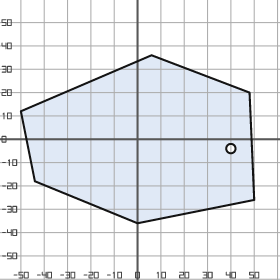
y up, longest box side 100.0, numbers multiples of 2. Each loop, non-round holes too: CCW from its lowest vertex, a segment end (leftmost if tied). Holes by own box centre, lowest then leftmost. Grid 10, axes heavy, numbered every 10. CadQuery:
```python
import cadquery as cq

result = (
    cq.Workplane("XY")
    .moveTo(0.0, -36.0)
    .lineTo(50.0, -26.0)
    .lineTo(48.0, 20.0)
    .lineTo(6.0, 36.0)
    .lineTo(-50.0, 12.0)
    .lineTo(-44.0, -18.0)
    .close()
    .moveTo(40.0, -4.0)
    .circle(2.0)
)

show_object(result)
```